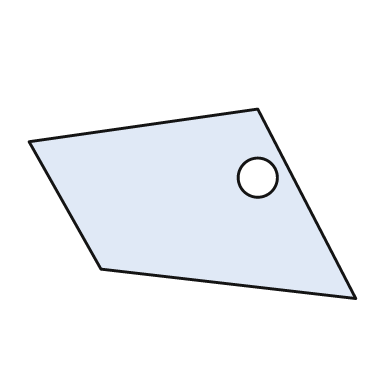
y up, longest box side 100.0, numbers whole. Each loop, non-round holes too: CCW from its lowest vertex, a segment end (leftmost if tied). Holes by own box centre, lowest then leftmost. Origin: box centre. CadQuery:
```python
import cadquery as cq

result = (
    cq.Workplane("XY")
    .moveTo(50.0, -29.0)
    .lineTo(20.0, 29.0)
    .lineTo(-50.0, 19.0)
    .lineTo(-28.0, -20.0)
    .close()
    .moveTo(20.0, 8.0)
    .circle(6.0)
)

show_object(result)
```